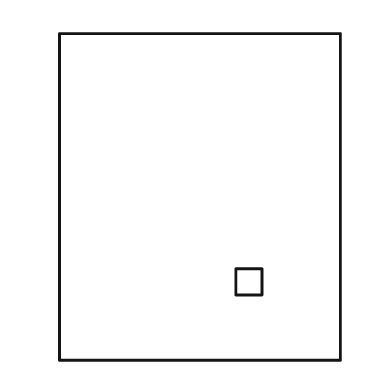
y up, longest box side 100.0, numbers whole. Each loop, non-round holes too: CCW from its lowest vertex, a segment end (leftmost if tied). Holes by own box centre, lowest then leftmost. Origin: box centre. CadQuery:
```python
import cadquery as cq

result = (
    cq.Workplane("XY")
    .moveTo(-43.0, -50.0)
    .lineTo(43.0, -50.0)
    .lineTo(43.0, 50.0)
    .lineTo(-43.0, 50.0)
    .close()
    .moveTo(11.0, -30.0)
    .lineTo(19.0, -30.0)
    .lineTo(19.0, -22.0)
    .lineTo(11.0, -22.0)
    .close()
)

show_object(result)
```